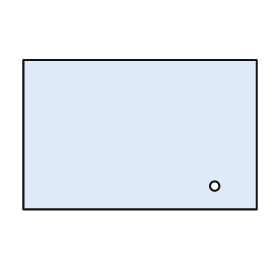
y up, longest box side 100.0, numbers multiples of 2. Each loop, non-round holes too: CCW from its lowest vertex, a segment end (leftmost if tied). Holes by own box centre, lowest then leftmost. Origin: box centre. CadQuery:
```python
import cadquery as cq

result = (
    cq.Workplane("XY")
    .moveTo(-50.0, -32.0)
    .lineTo(50.0, -32.0)
    .lineTo(50.0, 32.0)
    .lineTo(-50.0, 32.0)
    .close()
    .moveTo(32.0, -22.0)
    .circle(2.0)
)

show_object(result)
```